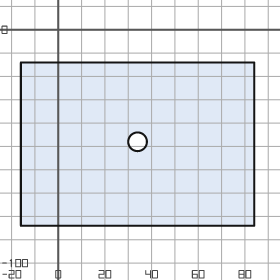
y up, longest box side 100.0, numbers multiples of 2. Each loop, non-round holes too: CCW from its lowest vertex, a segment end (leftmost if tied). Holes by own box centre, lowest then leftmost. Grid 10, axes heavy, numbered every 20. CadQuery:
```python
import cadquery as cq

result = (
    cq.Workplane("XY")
    .moveTo(-16.0, -84.0)
    .lineTo(84.0, -84.0)
    .lineTo(84.0, -14.0)
    .lineTo(-16.0, -14.0)
    .close()
    .moveTo(34.0, -48.0)
    .circle(4.0)
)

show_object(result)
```